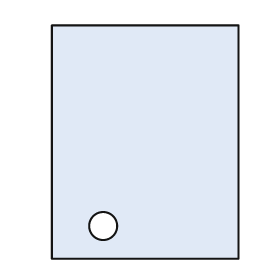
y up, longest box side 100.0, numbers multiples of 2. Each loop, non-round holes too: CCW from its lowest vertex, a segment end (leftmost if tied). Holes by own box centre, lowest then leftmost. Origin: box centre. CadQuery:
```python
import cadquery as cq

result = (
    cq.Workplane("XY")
    .moveTo(-40.0, -50.0)
    .lineTo(40.0, -50.0)
    .lineTo(40.0, 50.0)
    .lineTo(-40.0, 50.0)
    .close()
    .moveTo(-18.0, -36.0)
    .circle(6.0)
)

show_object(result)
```